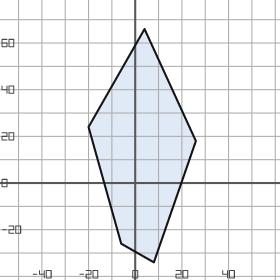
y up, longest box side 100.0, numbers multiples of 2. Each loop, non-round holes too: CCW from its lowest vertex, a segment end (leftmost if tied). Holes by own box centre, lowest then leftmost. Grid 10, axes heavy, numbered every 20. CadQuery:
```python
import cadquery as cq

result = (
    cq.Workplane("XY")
    .moveTo(8.0, -34.0)
    .lineTo(26.0, 18.0)
    .lineTo(4.0, 66.0)
    .lineTo(-20.0, 24.0)
    .lineTo(-6.0, -26.0)
    .close()
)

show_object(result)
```